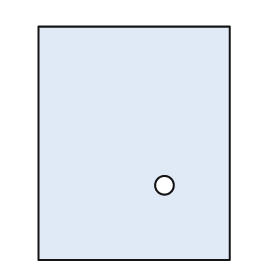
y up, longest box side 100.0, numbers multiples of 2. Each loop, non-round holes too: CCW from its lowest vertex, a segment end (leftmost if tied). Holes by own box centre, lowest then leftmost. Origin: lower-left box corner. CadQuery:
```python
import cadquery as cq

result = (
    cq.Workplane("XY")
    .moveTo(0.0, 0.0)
    .lineTo(82.0, 0.0)
    .lineTo(82.0, 100.0)
    .lineTo(0.0, 100.0)
    .close()
    .moveTo(54.0, 32.0)
    .circle(4.0)
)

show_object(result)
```